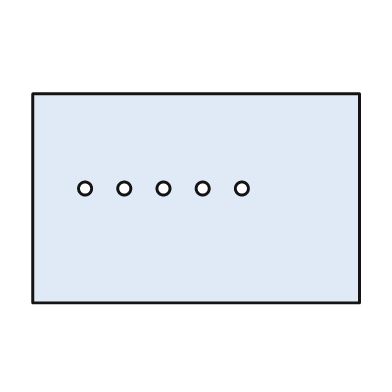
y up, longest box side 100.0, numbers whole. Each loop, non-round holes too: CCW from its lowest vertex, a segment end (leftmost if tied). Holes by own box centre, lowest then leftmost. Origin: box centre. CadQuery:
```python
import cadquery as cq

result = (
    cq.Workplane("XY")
    .moveTo(-50.0, -32.0)
    .lineTo(50.0, -32.0)
    .lineTo(50.0, 32.0)
    .lineTo(-50.0, 32.0)
    .close()
    .moveTo(-34.0, 3.0)
    .circle(2.0)
    .moveTo(-22.0, 3.0)
    .circle(2.0)
    .moveTo(-10.0, 3.0)
    .circle(2.0)
    .moveTo(2.0, 3.0)
    .circle(2.0)
    .moveTo(14.0, 3.0)
    .circle(2.0)
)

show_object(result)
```